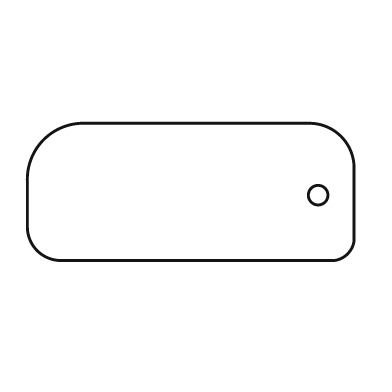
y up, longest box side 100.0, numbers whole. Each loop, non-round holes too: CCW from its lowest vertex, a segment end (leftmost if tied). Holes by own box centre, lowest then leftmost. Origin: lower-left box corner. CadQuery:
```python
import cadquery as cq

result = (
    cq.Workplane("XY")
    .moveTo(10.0, 0.0)
    .lineTo(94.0, 0.0)
    .threePointArc((98.0, 2.0), (100.0, 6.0))
    .lineTo(100.0, 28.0)
    .threePointArc((96.0, 38.0), (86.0, 42.0))
    .lineTo(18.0, 42.0)
    .threePointArc((5.0, 37.0), (0.0, 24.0))
    .lineTo(0.0, 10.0)
    .threePointArc((3.0, 3.0), (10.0, 0.0))
    .close()
    .moveTo(89.0, 20.0)
    .circle(3.0)
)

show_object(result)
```